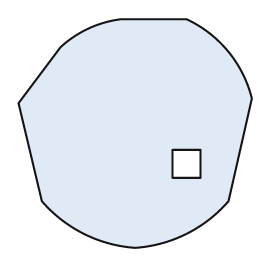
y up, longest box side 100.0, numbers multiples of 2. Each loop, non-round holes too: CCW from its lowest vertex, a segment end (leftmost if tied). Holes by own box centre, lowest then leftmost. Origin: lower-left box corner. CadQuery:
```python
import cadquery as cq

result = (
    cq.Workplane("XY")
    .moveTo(50.0, 0.0)
    .threePointArc((72.0, 6.0), (90.0, 20.0))
    .lineTo(100.0, 64.0)
    .threePointArc((90.0, 84.0), (72.0, 98.0))
    .lineTo(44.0, 98.0)
    .threePointArc((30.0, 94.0), (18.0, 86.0))
    .lineTo(0.0, 62.0)
    .lineTo(10.0, 20.0)
    .threePointArc((28.0, 6.0), (50.0, 0.0))
    .close()
    .moveTo(66.0, 30.0)
    .lineTo(78.0, 30.0)
    .lineTo(78.0, 42.0)
    .lineTo(66.0, 42.0)
    .close()
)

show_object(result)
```